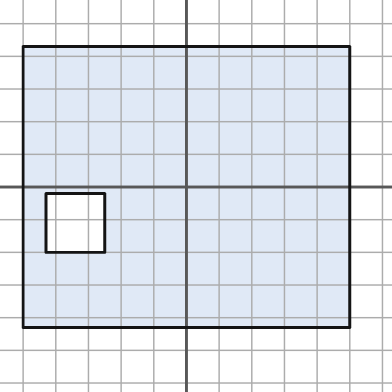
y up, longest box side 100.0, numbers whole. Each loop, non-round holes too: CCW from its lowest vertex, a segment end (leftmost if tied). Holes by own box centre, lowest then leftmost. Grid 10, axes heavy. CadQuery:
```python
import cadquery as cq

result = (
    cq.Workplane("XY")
    .moveTo(-50.0, -43.0)
    .lineTo(50.0, -43.0)
    .lineTo(50.0, 43.0)
    .lineTo(-50.0, 43.0)
    .close()
    .moveTo(-43.0, -20.0)
    .lineTo(-25.0, -20.0)
    .lineTo(-25.0, -2.0)
    .lineTo(-43.0, -2.0)
    .close()
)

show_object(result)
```